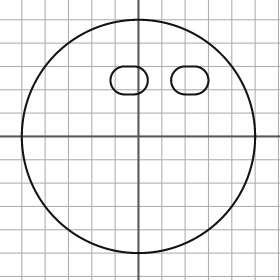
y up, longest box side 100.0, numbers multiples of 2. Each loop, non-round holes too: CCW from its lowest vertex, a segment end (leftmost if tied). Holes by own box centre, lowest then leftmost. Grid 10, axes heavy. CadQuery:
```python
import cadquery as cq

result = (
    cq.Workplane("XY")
    .moveTo(0.0, 0.0)
    .circle(50.0)
    .moveTo(-6.0, 18.0)
    .lineTo(-2.0, 18.0)
    .threePointArc((4.0, 24.0), (-2.0, 30.0))
    .lineTo(-6.0, 30.0)
    .threePointArc((-12.0, 24.0), (-6.0, 18.0))
    .close()
    .moveTo(20.0, 18.0)
    .lineTo(24.0, 18.0)
    .threePointArc((30.0, 24.0), (24.0, 30.0))
    .lineTo(20.0, 30.0)
    .threePointArc((14.0, 24.0), (20.0, 18.0))
    .close()
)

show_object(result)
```